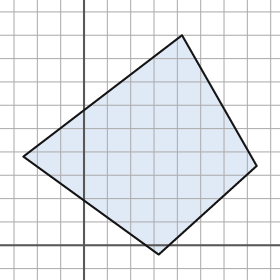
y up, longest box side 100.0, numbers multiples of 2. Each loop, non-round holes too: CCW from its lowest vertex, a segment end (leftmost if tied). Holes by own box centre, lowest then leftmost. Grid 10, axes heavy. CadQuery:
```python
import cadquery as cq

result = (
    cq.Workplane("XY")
    .moveTo(32.0, -4.0)
    .lineTo(74.0, 34.0)
    .lineTo(42.0, 90.0)
    .lineTo(-26.0, 38.0)
    .close()
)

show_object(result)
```